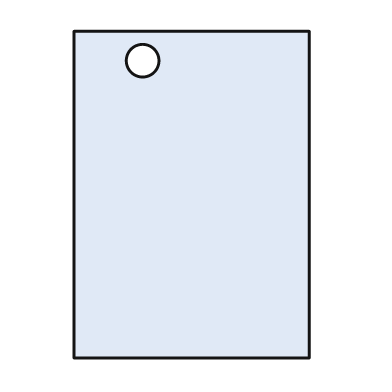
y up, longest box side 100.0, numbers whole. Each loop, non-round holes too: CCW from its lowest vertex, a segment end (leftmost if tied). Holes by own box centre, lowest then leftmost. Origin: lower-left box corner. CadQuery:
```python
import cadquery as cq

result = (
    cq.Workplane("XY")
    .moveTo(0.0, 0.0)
    .lineTo(72.0, 0.0)
    .lineTo(72.0, 100.0)
    .lineTo(0.0, 100.0)
    .close()
    .moveTo(21.0, 91.0)
    .circle(5.0)
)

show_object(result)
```